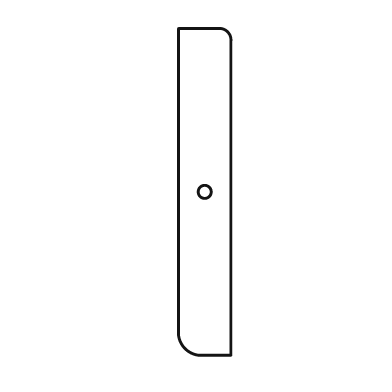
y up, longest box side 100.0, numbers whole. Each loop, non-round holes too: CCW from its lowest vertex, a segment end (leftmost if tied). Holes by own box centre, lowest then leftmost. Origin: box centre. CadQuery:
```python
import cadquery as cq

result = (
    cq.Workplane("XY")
    .moveTo(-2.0, -50.0)
    .lineTo(8.0, -50.0)
    .lineTo(8.0, 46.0)
    .threePointArc((7.0, 49.0), (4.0, 50.0))
    .lineTo(-8.0, 50.0)
    .lineTo(-8.0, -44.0)
    .threePointArc((-6.0, -48.0), (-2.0, -50.0))
    .close()
    .moveTo(0.0, 0.0)
    .circle(2.0)
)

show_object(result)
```